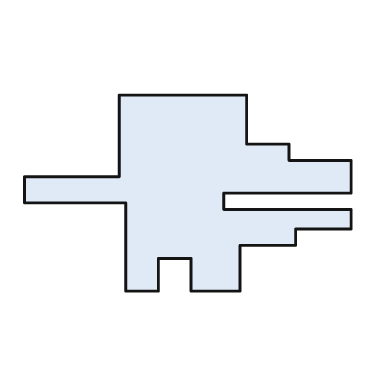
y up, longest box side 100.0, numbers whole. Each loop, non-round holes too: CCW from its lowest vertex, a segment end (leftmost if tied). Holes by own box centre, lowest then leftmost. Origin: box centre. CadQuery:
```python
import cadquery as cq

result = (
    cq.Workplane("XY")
    .moveTo(-19.0, -30.0)
    .lineTo(-9.0, -30.0)
    .lineTo(-9.0, -20.0)
    .lineTo(1.0, -20.0)
    .lineTo(1.0, -30.0)
    .lineTo(16.0, -30.0)
    .lineTo(16.0, -16.0)
    .lineTo(33.0, -16.0)
    .lineTo(33.0, -11.0)
    .lineTo(50.0, -11.0)
    .lineTo(50.0, -5.0)
    .lineTo(11.0, -5.0)
    .lineTo(11.0, 0.0)
    .lineTo(50.0, 0.0)
    .lineTo(50.0, 10.0)
    .lineTo(31.0, 10.0)
    .lineTo(31.0, 15.0)
    .lineTo(18.0, 15.0)
    .lineTo(18.0, 30.0)
    .lineTo(-21.0, 30.0)
    .lineTo(-21.0, 5.0)
    .lineTo(-50.0, 5.0)
    .lineTo(-50.0, -3.0)
    .lineTo(-19.0, -3.0)
    .close()
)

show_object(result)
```